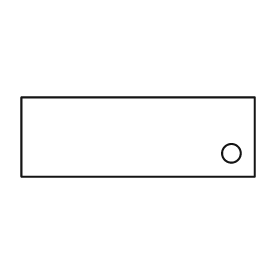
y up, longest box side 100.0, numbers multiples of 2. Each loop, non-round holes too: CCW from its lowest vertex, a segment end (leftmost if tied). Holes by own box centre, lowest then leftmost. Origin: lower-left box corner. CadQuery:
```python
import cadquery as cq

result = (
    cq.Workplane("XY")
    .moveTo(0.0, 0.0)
    .lineTo(100.0, 0.0)
    .lineTo(100.0, 34.0)
    .lineTo(0.0, 34.0)
    .close()
    .moveTo(90.0, 10.0)
    .circle(4.0)
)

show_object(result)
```